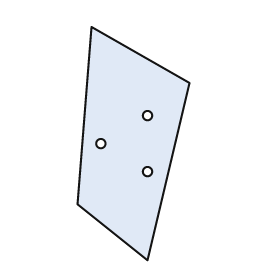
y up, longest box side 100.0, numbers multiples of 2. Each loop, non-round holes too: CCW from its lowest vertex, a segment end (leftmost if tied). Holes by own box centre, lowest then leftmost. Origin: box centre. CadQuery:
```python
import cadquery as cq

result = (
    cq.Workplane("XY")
    .moveTo(6.0, -50.0)
    .lineTo(24.0, 26.0)
    .lineTo(-18.0, 50.0)
    .lineTo(-24.0, -26.0)
    .close()
    .moveTo(6.0, -12.0)
    .circle(2.0)
    .moveTo(-14.0, 0.0)
    .circle(2.0)
    .moveTo(6.0, 12.0)
    .circle(2.0)
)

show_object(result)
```